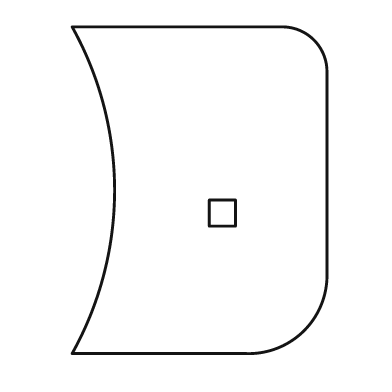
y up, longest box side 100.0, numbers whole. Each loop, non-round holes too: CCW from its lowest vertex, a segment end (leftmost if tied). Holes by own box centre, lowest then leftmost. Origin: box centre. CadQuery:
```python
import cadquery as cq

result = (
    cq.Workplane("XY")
    .moveTo(-39.0, -50.0)
    .lineTo(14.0, -50.0)
    .threePointArc((32.0, -43.0), (39.0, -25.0))
    .lineTo(39.0, 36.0)
    .threePointArc((35.0, 46.0), (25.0, 50.0))
    .lineTo(-39.0, 50.0)
    .threePointArc((-26.0, 0.0), (-39.0, -50.0))
    .close()
    .moveTo(3.0, -11.0)
    .lineTo(11.0, -11.0)
    .lineTo(11.0, -3.0)
    .lineTo(3.0, -3.0)
    .close()
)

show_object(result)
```